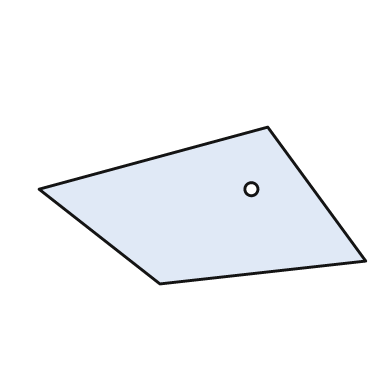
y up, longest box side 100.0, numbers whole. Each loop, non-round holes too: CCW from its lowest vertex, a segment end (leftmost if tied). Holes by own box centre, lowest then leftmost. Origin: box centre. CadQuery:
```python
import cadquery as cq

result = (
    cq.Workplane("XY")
    .moveTo(-13.0, -24.0)
    .lineTo(50.0, -17.0)
    .lineTo(20.0, 24.0)
    .lineTo(-50.0, 5.0)
    .close()
    .moveTo(15.0, 5.0)
    .circle(2.0)
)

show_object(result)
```